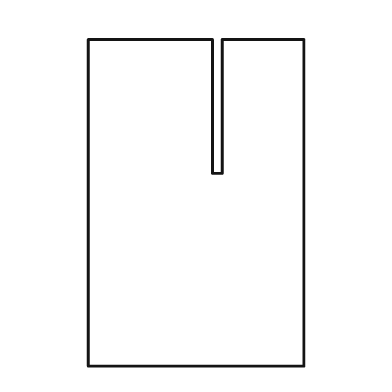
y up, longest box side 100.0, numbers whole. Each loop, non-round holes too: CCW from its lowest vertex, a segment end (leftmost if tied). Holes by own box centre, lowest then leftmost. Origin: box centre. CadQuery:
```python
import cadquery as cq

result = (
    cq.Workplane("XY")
    .moveTo(-33.0, -50.0)
    .lineTo(33.0, -50.0)
    .lineTo(33.0, 50.0)
    .lineTo(8.0, 50.0)
    .lineTo(8.0, 9.0)
    .lineTo(5.0, 9.0)
    .lineTo(5.0, 50.0)
    .lineTo(-33.0, 50.0)
    .close()
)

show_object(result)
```